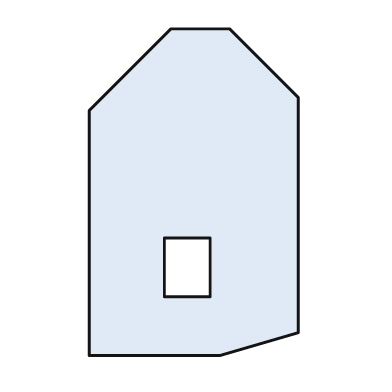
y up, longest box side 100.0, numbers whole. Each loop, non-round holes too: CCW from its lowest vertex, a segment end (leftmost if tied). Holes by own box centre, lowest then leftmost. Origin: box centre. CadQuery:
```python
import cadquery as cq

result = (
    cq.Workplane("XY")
    .moveTo(-32.0, -50.0)
    .lineTo(8.0, -50.0)
    .lineTo(32.0, -43.0)
    .lineTo(32.0, 29.0)
    .lineTo(11.0, 50.0)
    .lineTo(-7.0, 50.0)
    .lineTo(-32.0, 25.0)
    .close()
    .moveTo(-9.0, -32.0)
    .lineTo(5.0, -32.0)
    .lineTo(5.0, -14.0)
    .lineTo(-9.0, -14.0)
    .close()
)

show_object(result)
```